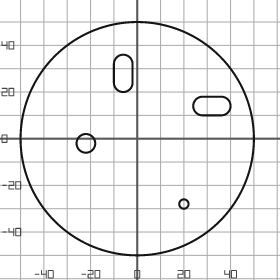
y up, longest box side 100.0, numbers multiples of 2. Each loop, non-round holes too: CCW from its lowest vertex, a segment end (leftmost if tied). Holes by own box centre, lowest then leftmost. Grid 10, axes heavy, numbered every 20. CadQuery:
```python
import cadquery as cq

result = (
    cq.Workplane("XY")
    .moveTo(0.0, 0.0)
    .circle(50.0)
    .moveTo(20.0, -28.0)
    .circle(2.0)
    .moveTo(-22.0, -2.0)
    .circle(4.0)
    .moveTo(28.0, 10.0)
    .lineTo(36.0, 10.0)
    .threePointArc((40.0, 14.0), (36.0, 18.0))
    .lineTo(28.0, 18.0)
    .threePointArc((24.0, 14.0), (28.0, 10.0))
    .close()
    .moveTo(-10.0, 24.0)
    .threePointArc((-6.0, 20.0), (-2.0, 24.0))
    .lineTo(-2.0, 32.0)
    .threePointArc((-6.0, 36.0), (-10.0, 32.0))
    .close()
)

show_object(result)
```